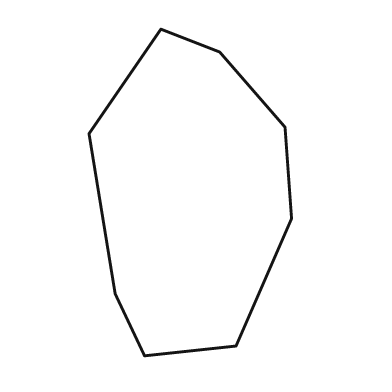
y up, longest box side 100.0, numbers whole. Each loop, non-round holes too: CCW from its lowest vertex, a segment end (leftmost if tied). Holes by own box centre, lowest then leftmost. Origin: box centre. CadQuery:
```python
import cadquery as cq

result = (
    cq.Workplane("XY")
    .moveTo(-14.0, -50.0)
    .lineTo(14.0, -47.0)
    .lineTo(31.0, -8.0)
    .lineTo(29.0, 20.0)
    .lineTo(9.0, 43.0)
    .lineTo(-9.0, 50.0)
    .lineTo(-31.0, 18.0)
    .lineTo(-23.0, -31.0)
    .close()
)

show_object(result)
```